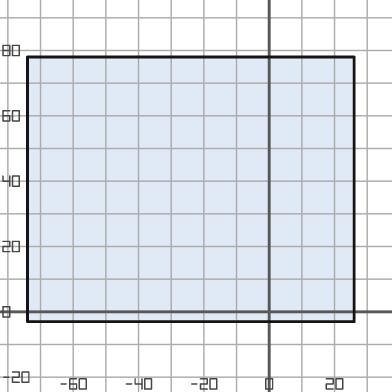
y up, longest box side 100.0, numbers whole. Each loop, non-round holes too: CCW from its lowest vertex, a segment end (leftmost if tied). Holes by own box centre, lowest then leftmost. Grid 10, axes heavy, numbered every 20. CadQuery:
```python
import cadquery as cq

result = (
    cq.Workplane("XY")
    .moveTo(-74.0, -3.0)
    .lineTo(26.0, -3.0)
    .lineTo(26.0, 78.0)
    .lineTo(-74.0, 78.0)
    .close()
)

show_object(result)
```